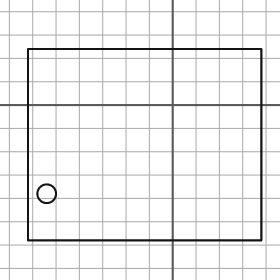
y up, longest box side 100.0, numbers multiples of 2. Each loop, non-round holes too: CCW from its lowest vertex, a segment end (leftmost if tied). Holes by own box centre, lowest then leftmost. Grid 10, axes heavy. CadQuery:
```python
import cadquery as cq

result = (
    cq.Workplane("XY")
    .moveTo(-62.0, -58.0)
    .lineTo(38.0, -58.0)
    .lineTo(38.0, 24.0)
    .lineTo(-62.0, 24.0)
    .close()
    .moveTo(-54.0, -38.0)
    .circle(4.0)
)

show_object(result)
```